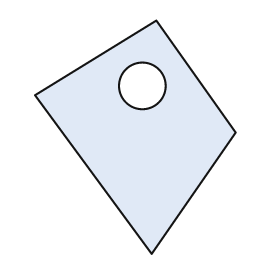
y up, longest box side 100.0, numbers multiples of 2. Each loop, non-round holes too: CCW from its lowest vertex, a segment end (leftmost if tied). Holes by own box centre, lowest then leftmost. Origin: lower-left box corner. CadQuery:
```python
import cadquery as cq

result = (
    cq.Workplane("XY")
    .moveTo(50.0, 0.0)
    .lineTo(86.0, 52.0)
    .lineTo(52.0, 100.0)
    .lineTo(0.0, 68.0)
    .close()
    .moveTo(46.0, 72.0)
    .circle(10.0)
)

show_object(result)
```